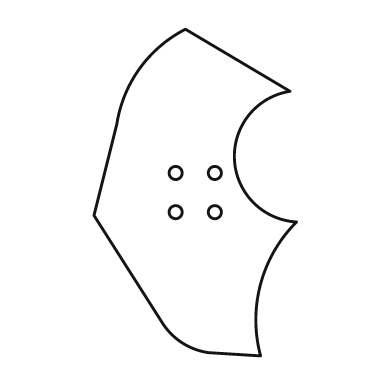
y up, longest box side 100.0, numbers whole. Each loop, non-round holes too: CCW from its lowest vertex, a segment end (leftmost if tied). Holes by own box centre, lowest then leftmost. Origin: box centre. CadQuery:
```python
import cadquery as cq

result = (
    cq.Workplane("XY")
    .moveTo(20.0, -50.0)
    .threePointArc((20.0, -28.0), (31.0, -9.0))
    .threePointArc((12.0, 10.0), (29.0, 31.0))
    .lineTo(-3.0, 50.0)
    .threePointArc((-17.0, 38.0), (-24.0, 21.0))
    .lineTo(-31.0, -7.0)
    .lineTo(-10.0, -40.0)
    .threePointArc((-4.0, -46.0), (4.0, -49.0))
    .close()
    .moveTo(-6.0, -6.0)
    .circle(2.0)
    .moveTo(6.0, -6.0)
    .circle(2.0)
    .moveTo(-6.0, 6.0)
    .circle(2.0)
    .moveTo(6.0, 6.0)
    .circle(2.0)
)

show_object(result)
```